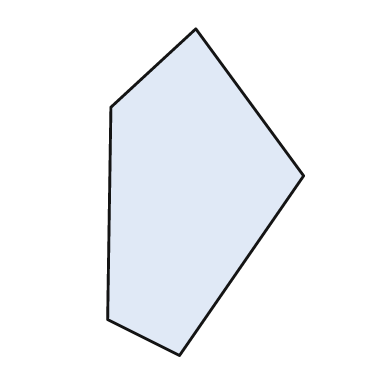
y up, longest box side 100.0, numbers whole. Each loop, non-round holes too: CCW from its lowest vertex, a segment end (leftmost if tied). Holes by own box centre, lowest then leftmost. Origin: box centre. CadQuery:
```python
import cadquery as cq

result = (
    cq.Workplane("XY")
    .moveTo(-8.0, -50.0)
    .lineTo(30.0, 5.0)
    .lineTo(-3.0, 50.0)
    .lineTo(-29.0, 26.0)
    .lineTo(-30.0, -39.0)
    .close()
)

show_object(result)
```